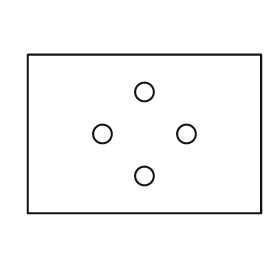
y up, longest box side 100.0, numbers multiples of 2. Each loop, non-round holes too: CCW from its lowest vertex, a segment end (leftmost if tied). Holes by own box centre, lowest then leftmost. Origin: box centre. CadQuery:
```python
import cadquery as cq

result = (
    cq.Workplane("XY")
    .moveTo(-50.0, -34.0)
    .lineTo(50.0, -34.0)
    .lineTo(50.0, 34.0)
    .lineTo(-50.0, 34.0)
    .close()
    .moveTo(0.0, -18.0)
    .circle(4.0)
    .moveTo(-18.0, 0.0)
    .circle(4.0)
    .moveTo(18.0, 0.0)
    .circle(4.0)
    .moveTo(0.0, 18.0)
    .circle(4.0)
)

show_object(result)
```